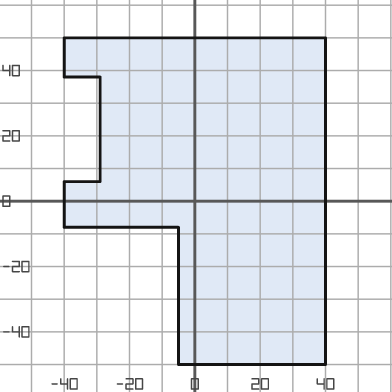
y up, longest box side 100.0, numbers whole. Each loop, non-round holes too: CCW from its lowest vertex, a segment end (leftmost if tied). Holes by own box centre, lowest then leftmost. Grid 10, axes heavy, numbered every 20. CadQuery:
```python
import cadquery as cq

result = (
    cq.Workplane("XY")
    .moveTo(-5.0, -50.0)
    .lineTo(40.0, -50.0)
    .lineTo(40.0, 50.0)
    .lineTo(-40.0, 50.0)
    .lineTo(-40.0, 38.0)
    .lineTo(-29.0, 38.0)
    .lineTo(-29.0, 6.0)
    .lineTo(-40.0, 6.0)
    .lineTo(-40.0, -8.0)
    .lineTo(-5.0, -8.0)
    .close()
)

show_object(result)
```